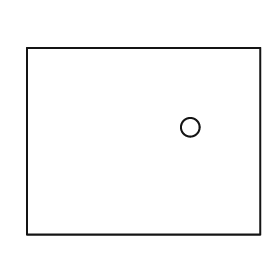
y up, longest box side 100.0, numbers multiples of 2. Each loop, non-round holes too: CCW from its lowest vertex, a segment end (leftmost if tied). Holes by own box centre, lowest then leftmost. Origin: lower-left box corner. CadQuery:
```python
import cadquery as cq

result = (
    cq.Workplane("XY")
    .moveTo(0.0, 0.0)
    .lineTo(100.0, 0.0)
    .lineTo(100.0, 80.0)
    .lineTo(0.0, 80.0)
    .close()
    .moveTo(70.0, 46.0)
    .circle(4.0)
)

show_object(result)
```